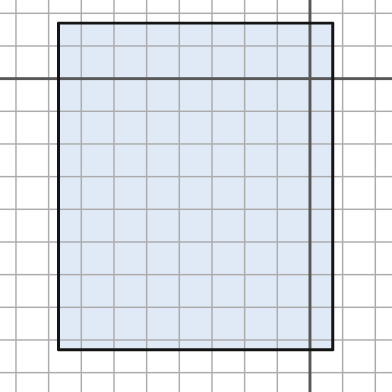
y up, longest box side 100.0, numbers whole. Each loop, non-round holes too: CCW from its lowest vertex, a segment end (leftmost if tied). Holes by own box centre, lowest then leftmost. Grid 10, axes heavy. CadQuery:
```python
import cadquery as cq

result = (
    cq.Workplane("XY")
    .moveTo(-77.0, -83.0)
    .lineTo(7.0, -83.0)
    .lineTo(7.0, 17.0)
    .lineTo(-77.0, 17.0)
    .close()
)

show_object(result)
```